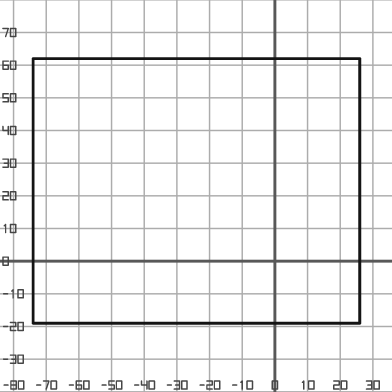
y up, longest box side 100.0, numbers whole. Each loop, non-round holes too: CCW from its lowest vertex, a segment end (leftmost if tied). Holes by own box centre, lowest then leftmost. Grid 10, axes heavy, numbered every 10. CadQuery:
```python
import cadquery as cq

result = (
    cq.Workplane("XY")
    .moveTo(-74.0, -19.0)
    .lineTo(26.0, -19.0)
    .lineTo(26.0, 62.0)
    .lineTo(-74.0, 62.0)
    .close()
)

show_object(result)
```